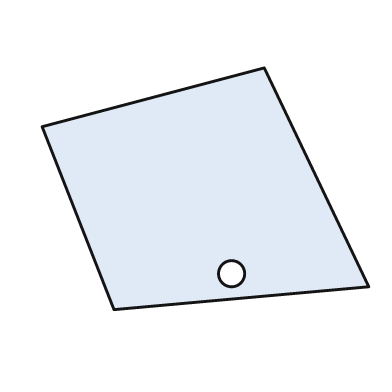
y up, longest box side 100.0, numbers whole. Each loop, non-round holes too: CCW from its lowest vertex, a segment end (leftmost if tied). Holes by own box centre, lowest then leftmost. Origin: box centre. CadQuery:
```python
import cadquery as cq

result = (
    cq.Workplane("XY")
    .moveTo(-28.0, -37.0)
    .lineTo(50.0, -30.0)
    .lineTo(18.0, 37.0)
    .lineTo(-50.0, 19.0)
    .close()
    .moveTo(8.0, -26.0)
    .circle(4.0)
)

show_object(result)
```